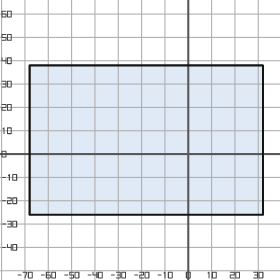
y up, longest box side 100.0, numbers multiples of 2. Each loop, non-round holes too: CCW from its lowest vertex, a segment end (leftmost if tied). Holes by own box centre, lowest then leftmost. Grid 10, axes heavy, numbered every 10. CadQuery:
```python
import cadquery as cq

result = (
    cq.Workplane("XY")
    .moveTo(-68.0, -26.0)
    .lineTo(32.0, -26.0)
    .lineTo(32.0, 38.0)
    .lineTo(-68.0, 38.0)
    .close()
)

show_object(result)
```